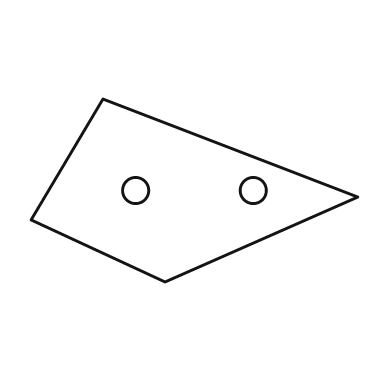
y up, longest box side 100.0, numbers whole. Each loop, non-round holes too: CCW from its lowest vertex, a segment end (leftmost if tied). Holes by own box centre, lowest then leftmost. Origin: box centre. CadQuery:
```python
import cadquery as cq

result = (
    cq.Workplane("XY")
    .moveTo(-9.0, -28.0)
    .lineTo(50.0, -2.0)
    .lineTo(-28.0, 28.0)
    .lineTo(-50.0, -9.0)
    .close()
    .moveTo(-18.0, 0.0)
    .circle(4.0)
    .moveTo(18.0, 0.0)
    .circle(4.0)
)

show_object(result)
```